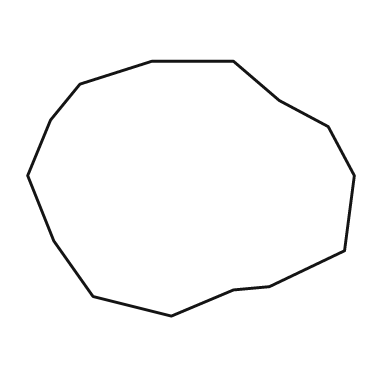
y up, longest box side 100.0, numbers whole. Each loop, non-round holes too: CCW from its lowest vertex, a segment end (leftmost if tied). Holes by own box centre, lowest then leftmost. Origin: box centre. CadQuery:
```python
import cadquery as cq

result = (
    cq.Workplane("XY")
    .moveTo(-6.0, -39.0)
    .lineTo(13.0, -31.0)
    .lineTo(24.0, -30.0)
    .lineTo(47.0, -19.0)
    .lineTo(50.0, 4.0)
    .lineTo(42.0, 19.0)
    .lineTo(27.0, 27.0)
    .lineTo(13.0, 39.0)
    .lineTo(-12.0, 39.0)
    .lineTo(-34.0, 32.0)
    .lineTo(-43.0, 21.0)
    .lineTo(-50.0, 4.0)
    .lineTo(-42.0, -16.0)
    .lineTo(-30.0, -33.0)
    .close()
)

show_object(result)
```